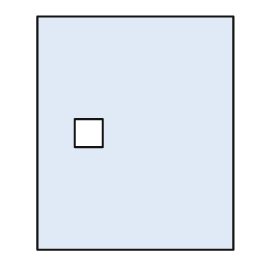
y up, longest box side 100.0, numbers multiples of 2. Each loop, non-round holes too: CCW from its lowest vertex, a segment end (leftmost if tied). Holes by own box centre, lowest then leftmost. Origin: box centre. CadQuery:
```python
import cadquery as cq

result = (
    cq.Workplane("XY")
    .moveTo(-42.0, -50.0)
    .lineTo(42.0, -50.0)
    .lineTo(42.0, 50.0)
    .lineTo(-42.0, 50.0)
    .close()
    .moveTo(-26.0, -6.0)
    .lineTo(-14.0, -6.0)
    .lineTo(-14.0, 6.0)
    .lineTo(-26.0, 6.0)
    .close()
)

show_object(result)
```